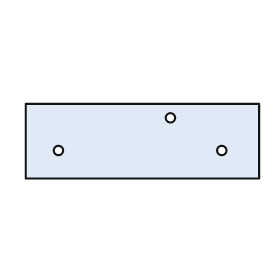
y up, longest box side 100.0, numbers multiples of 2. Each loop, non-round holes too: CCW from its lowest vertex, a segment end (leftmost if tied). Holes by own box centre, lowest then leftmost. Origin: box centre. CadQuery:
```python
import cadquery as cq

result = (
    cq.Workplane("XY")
    .moveTo(-50.0, -16.0)
    .lineTo(50.0, -16.0)
    .lineTo(50.0, 16.0)
    .lineTo(-50.0, 16.0)
    .close()
    .moveTo(-36.0, -4.0)
    .circle(2.0)
    .moveTo(34.0, -4.0)
    .circle(2.0)
    .moveTo(12.0, 10.0)
    .circle(2.0)
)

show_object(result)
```